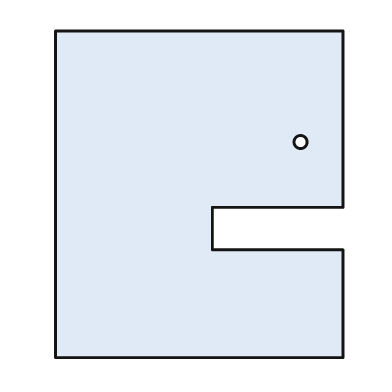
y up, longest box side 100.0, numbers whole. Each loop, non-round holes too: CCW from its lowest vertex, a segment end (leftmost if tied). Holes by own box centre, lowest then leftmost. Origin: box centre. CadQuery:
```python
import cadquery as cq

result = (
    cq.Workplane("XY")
    .moveTo(-44.0, -50.0)
    .lineTo(44.0, -50.0)
    .lineTo(44.0, -17.0)
    .lineTo(4.0, -17.0)
    .lineTo(4.0, -4.0)
    .lineTo(44.0, -4.0)
    .lineTo(44.0, 50.0)
    .lineTo(-44.0, 50.0)
    .close()
    .moveTo(31.0, 16.0)
    .circle(2.0)
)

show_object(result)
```